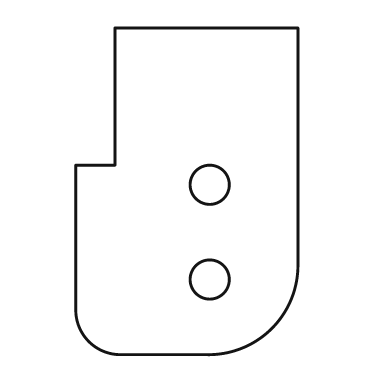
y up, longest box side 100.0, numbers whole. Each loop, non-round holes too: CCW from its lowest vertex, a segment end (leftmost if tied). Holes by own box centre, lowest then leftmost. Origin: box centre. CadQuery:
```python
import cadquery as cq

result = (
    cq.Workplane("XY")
    .moveTo(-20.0, -50.0)
    .lineTo(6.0, -50.0)
    .threePointArc((26.0, -42.0), (34.0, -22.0))
    .lineTo(34.0, 50.0)
    .lineTo(-22.0, 50.0)
    .lineTo(-22.0, 8.0)
    .lineTo(-34.0, 8.0)
    .lineTo(-34.0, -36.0)
    .threePointArc((-30.0, -46.0), (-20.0, -50.0))
    .close()
    .moveTo(7.0, -27.0)
    .circle(6.0)
    .moveTo(7.0, 2.0)
    .circle(6.0)
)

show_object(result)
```